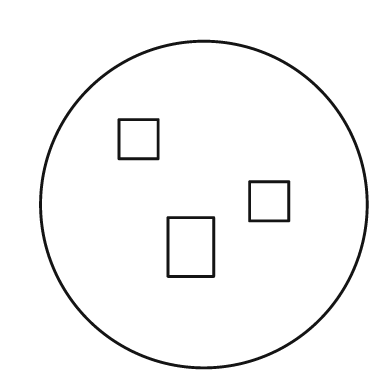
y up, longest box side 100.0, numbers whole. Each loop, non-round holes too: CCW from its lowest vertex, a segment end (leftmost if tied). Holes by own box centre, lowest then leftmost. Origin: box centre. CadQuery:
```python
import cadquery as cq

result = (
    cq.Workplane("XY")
    .moveTo(0.0, 0.0)
    .circle(50.0)
    .moveTo(-11.0, -22.0)
    .lineTo(3.0, -22.0)
    .lineTo(3.0, -4.0)
    .lineTo(-11.0, -4.0)
    .close()
    .moveTo(14.0, -5.0)
    .lineTo(26.0, -5.0)
    .lineTo(26.0, 7.0)
    .lineTo(14.0, 7.0)
    .close()
    .moveTo(-26.0, 14.0)
    .lineTo(-14.0, 14.0)
    .lineTo(-14.0, 26.0)
    .lineTo(-26.0, 26.0)
    .close()
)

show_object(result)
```